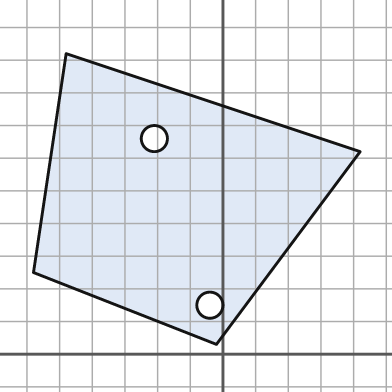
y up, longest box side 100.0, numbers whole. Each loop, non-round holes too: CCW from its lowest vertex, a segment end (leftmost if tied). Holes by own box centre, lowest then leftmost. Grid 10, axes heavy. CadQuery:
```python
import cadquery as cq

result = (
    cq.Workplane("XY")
    .moveTo(-2.0, 3.0)
    .lineTo(42.0, 62.0)
    .lineTo(-48.0, 92.0)
    .lineTo(-58.0, 25.0)
    .close()
    .moveTo(-4.0, 15.0)
    .circle(4.0)
    .moveTo(-21.0, 66.0)
    .circle(4.0)
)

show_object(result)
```